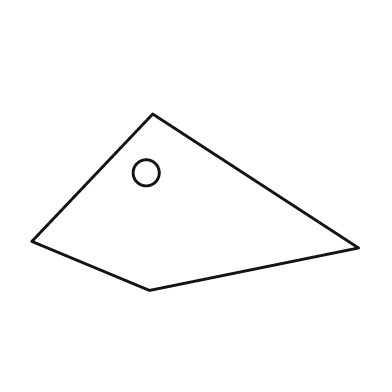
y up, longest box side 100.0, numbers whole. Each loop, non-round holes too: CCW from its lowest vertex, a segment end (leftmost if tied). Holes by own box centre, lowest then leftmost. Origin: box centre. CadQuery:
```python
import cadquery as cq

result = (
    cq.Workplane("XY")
    .moveTo(-14.0, -27.0)
    .lineTo(50.0, -14.0)
    .lineTo(-13.0, 27.0)
    .lineTo(-50.0, -12.0)
    .close()
    .moveTo(-15.0, 9.0)
    .circle(4.0)
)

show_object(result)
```